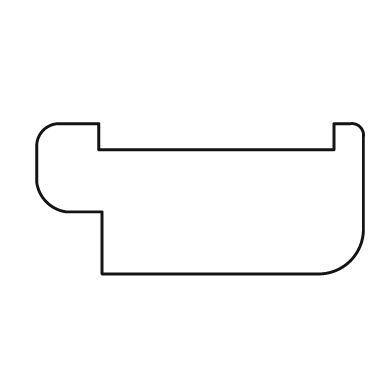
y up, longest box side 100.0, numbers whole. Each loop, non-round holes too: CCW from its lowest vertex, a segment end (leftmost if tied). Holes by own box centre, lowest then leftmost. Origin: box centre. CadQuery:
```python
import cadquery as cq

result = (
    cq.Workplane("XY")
    .moveTo(-30.0, -23.0)
    .lineTo(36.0, -23.0)
    .threePointArc((46.0, -19.0), (50.0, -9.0))
    .lineTo(50.0, 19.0)
    .threePointArc((49.0, 22.0), (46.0, 23.0))
    .lineTo(41.0, 23.0)
    .lineTo(41.0, 15.0)
    .lineTo(-31.0, 15.0)
    .lineTo(-31.0, 23.0)
    .lineTo(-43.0, 23.0)
    .threePointArc((-48.0, 21.0), (-50.0, 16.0))
    .lineTo(-50.0, 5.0)
    .threePointArc((-47.0, -1.0), (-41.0, -4.0))
    .lineTo(-30.0, -4.0)
    .close()
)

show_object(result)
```